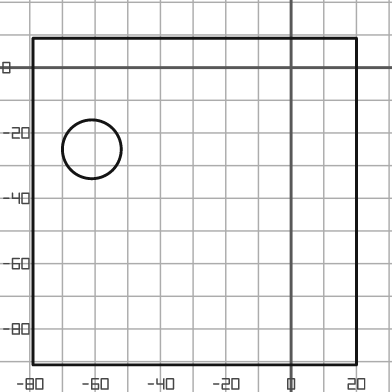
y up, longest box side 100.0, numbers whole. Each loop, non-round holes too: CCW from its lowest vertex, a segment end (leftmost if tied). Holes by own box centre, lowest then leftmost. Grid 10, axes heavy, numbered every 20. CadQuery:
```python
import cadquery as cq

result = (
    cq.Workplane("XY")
    .moveTo(-79.0, -91.0)
    .lineTo(20.0, -91.0)
    .lineTo(20.0, 9.0)
    .lineTo(-79.0, 9.0)
    .close()
    .moveTo(-61.0, -25.0)
    .circle(9.0)
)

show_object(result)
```